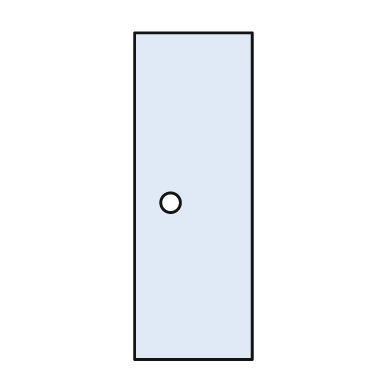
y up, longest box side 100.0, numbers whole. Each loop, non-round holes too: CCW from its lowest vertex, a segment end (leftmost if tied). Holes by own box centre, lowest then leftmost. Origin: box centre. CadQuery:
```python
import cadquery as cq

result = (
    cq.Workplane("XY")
    .moveTo(-18.0, -50.0)
    .lineTo(18.0, -50.0)
    .lineTo(18.0, 50.0)
    .lineTo(-18.0, 50.0)
    .close()
    .moveTo(-7.0, -2.0)
    .circle(3.0)
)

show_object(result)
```